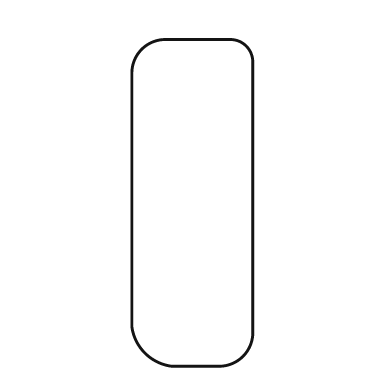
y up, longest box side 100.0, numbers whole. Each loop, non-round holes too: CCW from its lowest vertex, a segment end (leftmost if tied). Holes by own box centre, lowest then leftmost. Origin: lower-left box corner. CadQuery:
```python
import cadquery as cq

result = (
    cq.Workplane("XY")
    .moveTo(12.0, 0.0)
    .lineTo(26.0, 0.0)
    .threePointArc((34.0, 3.0), (37.0, 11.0))
    .lineTo(37.0, 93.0)
    .threePointArc((35.0, 98.0), (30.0, 100.0))
    .lineTo(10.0, 100.0)
    .threePointArc((3.0, 97.0), (0.0, 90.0))
    .lineTo(0.0, 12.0)
    .threePointArc((4.0, 4.0), (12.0, 0.0))
    .close()
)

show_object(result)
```